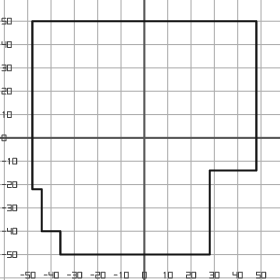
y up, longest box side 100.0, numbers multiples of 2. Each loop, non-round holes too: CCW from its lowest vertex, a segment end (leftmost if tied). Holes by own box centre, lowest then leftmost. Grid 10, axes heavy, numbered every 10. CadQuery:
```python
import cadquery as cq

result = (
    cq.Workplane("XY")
    .moveTo(-36.0, -50.0)
    .lineTo(28.0, -50.0)
    .lineTo(28.0, -14.0)
    .lineTo(48.0, -14.0)
    .lineTo(48.0, 50.0)
    .lineTo(-48.0, 50.0)
    .lineTo(-48.0, -22.0)
    .lineTo(-44.0, -22.0)
    .lineTo(-44.0, -40.0)
    .lineTo(-36.0, -40.0)
    .close()
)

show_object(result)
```